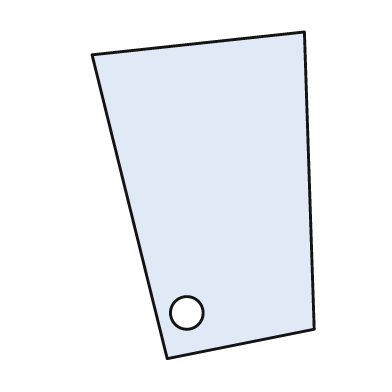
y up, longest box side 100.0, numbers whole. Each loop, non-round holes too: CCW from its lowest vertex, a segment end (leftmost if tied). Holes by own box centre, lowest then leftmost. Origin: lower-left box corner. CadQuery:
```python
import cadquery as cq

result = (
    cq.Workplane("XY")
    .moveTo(23.0, 0.0)
    .lineTo(68.0, 9.0)
    .lineTo(65.0, 100.0)
    .lineTo(0.0, 93.0)
    .close()
    .moveTo(29.0, 14.0)
    .circle(5.0)
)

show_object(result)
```